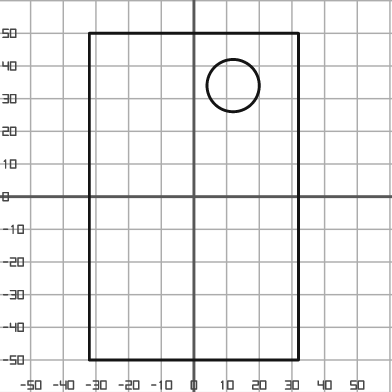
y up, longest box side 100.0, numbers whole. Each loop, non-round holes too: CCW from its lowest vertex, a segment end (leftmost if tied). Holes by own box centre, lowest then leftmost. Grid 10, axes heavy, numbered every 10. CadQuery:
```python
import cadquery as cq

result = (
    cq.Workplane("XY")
    .moveTo(-32.0, -50.0)
    .lineTo(32.0, -50.0)
    .lineTo(32.0, 50.0)
    .lineTo(-32.0, 50.0)
    .close()
    .moveTo(12.0, 34.0)
    .circle(8.0)
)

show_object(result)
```